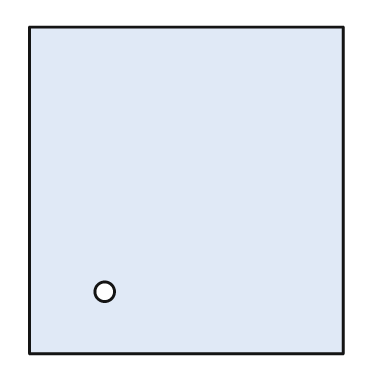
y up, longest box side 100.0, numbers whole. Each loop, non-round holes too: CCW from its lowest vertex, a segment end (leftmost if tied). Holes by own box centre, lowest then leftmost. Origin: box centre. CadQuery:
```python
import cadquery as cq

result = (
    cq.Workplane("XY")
    .moveTo(-48.0, -50.0)
    .lineTo(48.0, -50.0)
    .lineTo(48.0, 50.0)
    .lineTo(-48.0, 50.0)
    .close()
    .moveTo(-25.0, -31.0)
    .circle(3.0)
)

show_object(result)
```